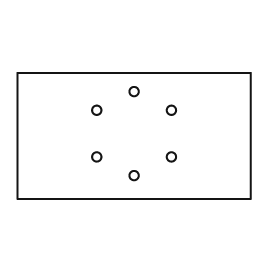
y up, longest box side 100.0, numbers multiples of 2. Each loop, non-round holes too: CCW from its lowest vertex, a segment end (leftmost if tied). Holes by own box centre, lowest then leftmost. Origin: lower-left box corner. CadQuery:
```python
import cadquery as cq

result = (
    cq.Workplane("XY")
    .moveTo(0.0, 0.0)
    .lineTo(100.0, 0.0)
    .lineTo(100.0, 54.0)
    .lineTo(0.0, 54.0)
    .close()
    .moveTo(50.0, 10.0)
    .circle(2.0)
    .moveTo(34.0, 18.0)
    .circle(2.0)
    .moveTo(66.0, 18.0)
    .circle(2.0)
    .moveTo(34.0, 38.0)
    .circle(2.0)
    .moveTo(66.0, 38.0)
    .circle(2.0)
    .moveTo(50.0, 46.0)
    .circle(2.0)
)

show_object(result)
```